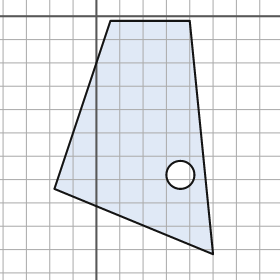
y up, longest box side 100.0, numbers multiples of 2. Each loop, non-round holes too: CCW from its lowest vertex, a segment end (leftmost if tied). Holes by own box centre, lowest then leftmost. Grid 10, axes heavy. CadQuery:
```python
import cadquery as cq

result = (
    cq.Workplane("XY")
    .moveTo(50.0, -102.0)
    .lineTo(40.0, -2.0)
    .lineTo(6.0, -2.0)
    .lineTo(-18.0, -74.0)
    .close()
    .moveTo(36.0, -68.0)
    .circle(6.0)
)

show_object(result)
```